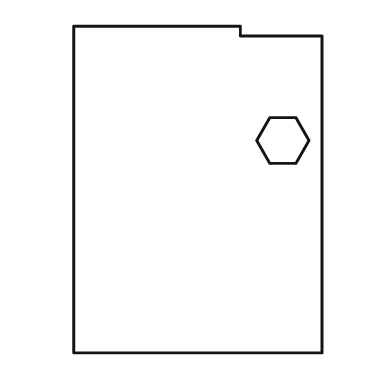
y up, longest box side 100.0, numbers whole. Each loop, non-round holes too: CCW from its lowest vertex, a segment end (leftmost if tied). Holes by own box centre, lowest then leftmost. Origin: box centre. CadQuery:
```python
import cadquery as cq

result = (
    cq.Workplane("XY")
    .moveTo(-38.0, -50.0)
    .lineTo(38.0, -50.0)
    .lineTo(38.0, 47.0)
    .lineTo(13.0, 47.0)
    .lineTo(13.0, 50.0)
    .lineTo(-38.0, 50.0)
    .close()
    .moveTo(22.0, 8.0)
    .lineTo(30.0, 8.0)
    .lineTo(34.0, 15.0)
    .lineTo(30.0, 22.0)
    .lineTo(22.0, 22.0)
    .lineTo(18.0, 15.0)
    .close()
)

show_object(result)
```